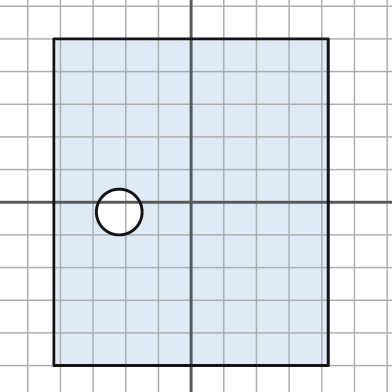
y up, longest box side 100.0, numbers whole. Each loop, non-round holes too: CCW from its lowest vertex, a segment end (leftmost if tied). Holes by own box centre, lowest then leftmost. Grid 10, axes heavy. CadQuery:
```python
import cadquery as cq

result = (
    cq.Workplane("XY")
    .moveTo(-42.0, -50.0)
    .lineTo(42.0, -50.0)
    .lineTo(42.0, 50.0)
    .lineTo(-42.0, 50.0)
    .close()
    .moveTo(-22.0, -3.0)
    .circle(7.0)
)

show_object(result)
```